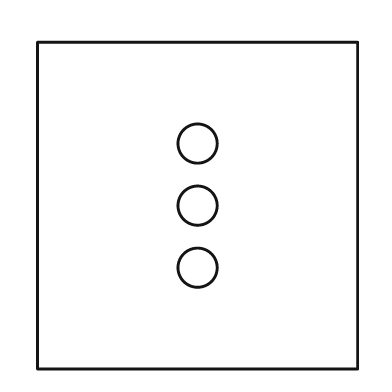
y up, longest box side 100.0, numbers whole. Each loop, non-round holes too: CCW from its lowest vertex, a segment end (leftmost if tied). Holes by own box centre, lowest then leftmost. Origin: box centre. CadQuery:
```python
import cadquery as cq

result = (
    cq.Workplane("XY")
    .moveTo(-49.0, -50.0)
    .lineTo(49.0, -50.0)
    .lineTo(49.0, 50.0)
    .lineTo(-49.0, 50.0)
    .close()
    .moveTo(0.0, -19.0)
    .circle(6.0)
    .moveTo(0.0, 0.0)
    .circle(6.0)
    .moveTo(0.0, 19.0)
    .circle(6.0)
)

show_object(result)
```